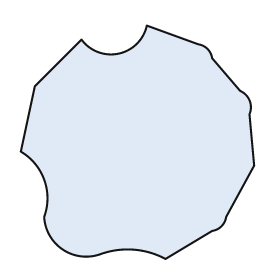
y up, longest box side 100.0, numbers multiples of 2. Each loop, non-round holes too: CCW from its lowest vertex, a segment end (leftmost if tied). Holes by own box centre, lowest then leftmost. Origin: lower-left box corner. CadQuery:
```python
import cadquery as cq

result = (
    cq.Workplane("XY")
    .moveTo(62.0, 0.0)
    .lineTo(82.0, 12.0)
    .threePointArc((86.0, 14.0), (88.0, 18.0))
    .lineTo(100.0, 40.0)
    .lineTo(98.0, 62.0)
    .threePointArc((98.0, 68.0), (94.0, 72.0))
    .lineTo(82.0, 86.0)
    .threePointArc((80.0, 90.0), (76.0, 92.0))
    .lineTo(54.0, 100.0)
    .threePointArc((42.0, 88.0), (26.0, 94.0))
    .lineTo(6.0, 74.0)
    .lineTo(0.0, 46.0)
    .threePointArc((10.0, 34.0), (10.0, 18.0))
    .threePointArc((18.0, 4.0), (34.0, 2.0))
    .threePointArc((48.0, 4.0), (62.0, 0.0))
    .close()
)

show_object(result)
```